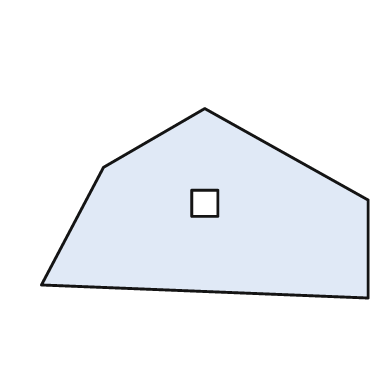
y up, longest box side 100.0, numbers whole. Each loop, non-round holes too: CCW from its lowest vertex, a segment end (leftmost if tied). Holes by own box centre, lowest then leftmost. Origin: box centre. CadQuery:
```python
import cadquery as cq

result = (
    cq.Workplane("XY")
    .moveTo(50.0, -29.0)
    .lineTo(50.0, 1.0)
    .lineTo(0.0, 29.0)
    .lineTo(-31.0, 11.0)
    .lineTo(-50.0, -25.0)
    .close()
    .moveTo(-4.0, -4.0)
    .lineTo(4.0, -4.0)
    .lineTo(4.0, 4.0)
    .lineTo(-4.0, 4.0)
    .close()
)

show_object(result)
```